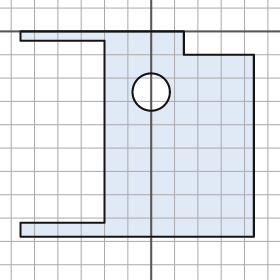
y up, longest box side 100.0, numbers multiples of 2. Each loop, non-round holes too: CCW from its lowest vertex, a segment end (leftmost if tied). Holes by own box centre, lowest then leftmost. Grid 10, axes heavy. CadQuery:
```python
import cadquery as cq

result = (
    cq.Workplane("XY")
    .moveTo(-56.0, -88.0)
    .lineTo(44.0, -88.0)
    .lineTo(44.0, -10.0)
    .lineTo(14.0, -10.0)
    .lineTo(14.0, 0.0)
    .lineTo(-56.0, 0.0)
    .lineTo(-56.0, -4.0)
    .lineTo(-20.0, -4.0)
    .lineTo(-20.0, -82.0)
    .lineTo(-56.0, -82.0)
    .close()
    .moveTo(0.0, -26.0)
    .circle(8.0)
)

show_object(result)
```